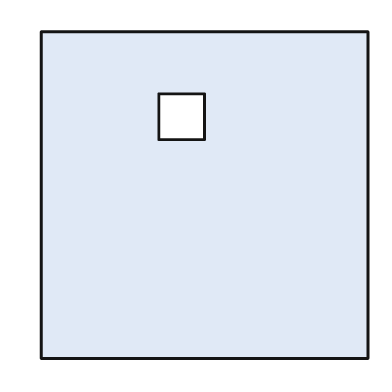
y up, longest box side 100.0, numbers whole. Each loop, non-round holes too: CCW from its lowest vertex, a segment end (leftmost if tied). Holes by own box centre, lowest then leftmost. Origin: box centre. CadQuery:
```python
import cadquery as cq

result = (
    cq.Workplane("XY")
    .moveTo(-50.0, -50.0)
    .lineTo(50.0, -50.0)
    .lineTo(50.0, 50.0)
    .lineTo(-50.0, 50.0)
    .close()
    .moveTo(-14.0, 17.0)
    .lineTo(0.0, 17.0)
    .lineTo(0.0, 31.0)
    .lineTo(-14.0, 31.0)
    .close()
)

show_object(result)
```